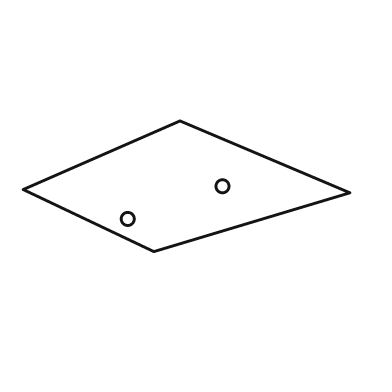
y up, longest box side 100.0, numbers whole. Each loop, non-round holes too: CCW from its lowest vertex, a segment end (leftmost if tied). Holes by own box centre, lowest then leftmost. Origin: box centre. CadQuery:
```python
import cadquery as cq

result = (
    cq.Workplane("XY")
    .moveTo(-10.0, -20.0)
    .lineTo(50.0, -2.0)
    .lineTo(-2.0, 20.0)
    .lineTo(-50.0, -1.0)
    .close()
    .moveTo(-18.0, -10.0)
    .circle(2.0)
    .moveTo(11.0, 0.0)
    .circle(2.0)
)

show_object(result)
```